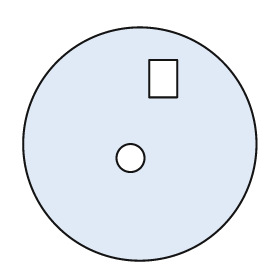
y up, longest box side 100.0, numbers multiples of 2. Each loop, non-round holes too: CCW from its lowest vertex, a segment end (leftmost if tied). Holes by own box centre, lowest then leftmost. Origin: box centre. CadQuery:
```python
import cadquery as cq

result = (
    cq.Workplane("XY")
    .moveTo(0.0, 0.0)
    .circle(50.0)
    .moveTo(-4.0, -6.0)
    .circle(6.0)
    .moveTo(4.0, 20.0)
    .lineTo(16.0, 20.0)
    .lineTo(16.0, 36.0)
    .lineTo(4.0, 36.0)
    .close()
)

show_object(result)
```